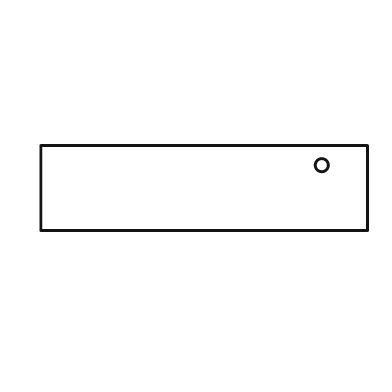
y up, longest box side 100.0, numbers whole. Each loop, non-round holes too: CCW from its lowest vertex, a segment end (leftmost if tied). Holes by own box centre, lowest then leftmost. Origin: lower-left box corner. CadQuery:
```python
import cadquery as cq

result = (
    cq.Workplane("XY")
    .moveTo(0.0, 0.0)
    .lineTo(100.0, 0.0)
    .lineTo(100.0, 26.0)
    .lineTo(0.0, 26.0)
    .close()
    .moveTo(86.0, 20.0)
    .circle(2.0)
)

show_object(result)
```